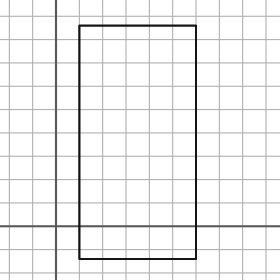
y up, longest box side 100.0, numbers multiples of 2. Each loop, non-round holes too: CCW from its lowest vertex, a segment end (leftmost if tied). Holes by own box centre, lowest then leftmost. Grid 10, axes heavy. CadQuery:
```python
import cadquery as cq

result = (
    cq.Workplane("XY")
    .moveTo(10.0, -14.0)
    .lineTo(60.0, -14.0)
    .lineTo(60.0, 86.0)
    .lineTo(10.0, 86.0)
    .close()
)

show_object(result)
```